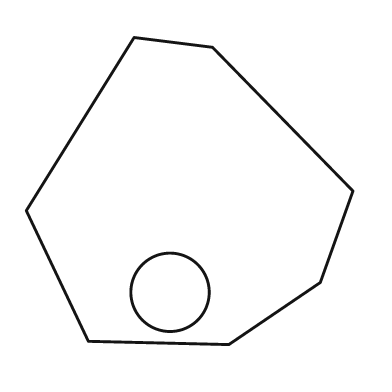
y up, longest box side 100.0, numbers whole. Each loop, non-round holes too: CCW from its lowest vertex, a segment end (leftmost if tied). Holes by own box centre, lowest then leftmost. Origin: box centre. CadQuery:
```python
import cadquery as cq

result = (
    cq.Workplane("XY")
    .moveTo(12.0, -47.0)
    .lineTo(40.0, -28.0)
    .lineTo(50.0, 0.0)
    .lineTo(7.0, 44.0)
    .lineTo(-17.0, 47.0)
    .lineTo(-50.0, -6.0)
    .lineTo(-31.0, -46.0)
    .close()
    .moveTo(-6.0, -31.0)
    .circle(12.0)
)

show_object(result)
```